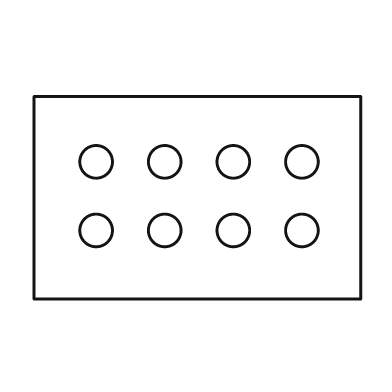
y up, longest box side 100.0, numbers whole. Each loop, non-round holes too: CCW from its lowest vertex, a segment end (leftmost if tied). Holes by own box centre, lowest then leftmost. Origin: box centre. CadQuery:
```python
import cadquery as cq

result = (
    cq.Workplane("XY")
    .moveTo(-50.0, -31.0)
    .lineTo(50.0, -31.0)
    .lineTo(50.0, 31.0)
    .lineTo(-50.0, 31.0)
    .close()
    .moveTo(-31.0, -10.0)
    .circle(5.0)
    .moveTo(-10.0, -10.0)
    .circle(5.0)
    .moveTo(11.0, -10.0)
    .circle(5.0)
    .moveTo(32.0, -10.0)
    .circle(5.0)
    .moveTo(-31.0, 11.0)
    .circle(5.0)
    .moveTo(-10.0, 11.0)
    .circle(5.0)
    .moveTo(11.0, 11.0)
    .circle(5.0)
    .moveTo(32.0, 11.0)
    .circle(5.0)
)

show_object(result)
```